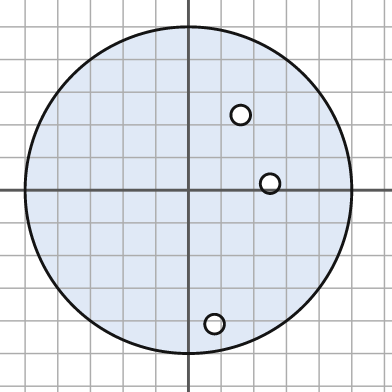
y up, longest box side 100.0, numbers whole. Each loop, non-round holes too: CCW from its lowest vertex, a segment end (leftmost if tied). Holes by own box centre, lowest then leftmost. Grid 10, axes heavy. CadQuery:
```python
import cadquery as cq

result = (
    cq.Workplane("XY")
    .moveTo(0.0, 0.0)
    .circle(50.0)
    .moveTo(8.0, -41.0)
    .circle(3.0)
    .moveTo(25.0, 2.0)
    .circle(3.0)
    .moveTo(16.0, 23.0)
    .circle(3.0)
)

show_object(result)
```